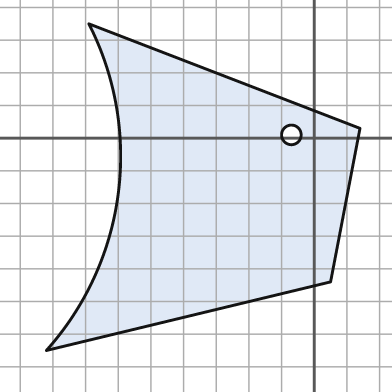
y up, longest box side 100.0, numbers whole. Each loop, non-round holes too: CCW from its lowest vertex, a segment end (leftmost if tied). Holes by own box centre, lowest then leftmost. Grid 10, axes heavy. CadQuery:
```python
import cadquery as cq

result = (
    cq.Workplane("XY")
    .moveTo(-82.0, -65.0)
    .lineTo(5.0, -44.0)
    .lineTo(14.0, 3.0)
    .lineTo(-69.0, 35.0)
    .threePointArc((-60.0, -17.0), (-82.0, -65.0))
    .close()
    .moveTo(-7.0, 1.0)
    .circle(3.0)
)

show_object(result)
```